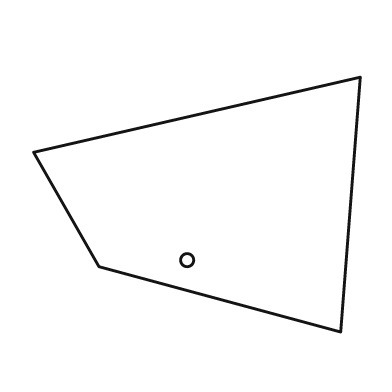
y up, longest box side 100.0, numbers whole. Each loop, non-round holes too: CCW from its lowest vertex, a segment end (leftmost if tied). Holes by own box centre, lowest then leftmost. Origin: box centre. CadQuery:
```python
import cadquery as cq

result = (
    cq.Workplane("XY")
    .moveTo(44.0, -39.0)
    .lineTo(50.0, 39.0)
    .lineTo(-50.0, 16.0)
    .lineTo(-30.0, -19.0)
    .close()
    .moveTo(-3.0, -17.0)
    .circle(2.0)
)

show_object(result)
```